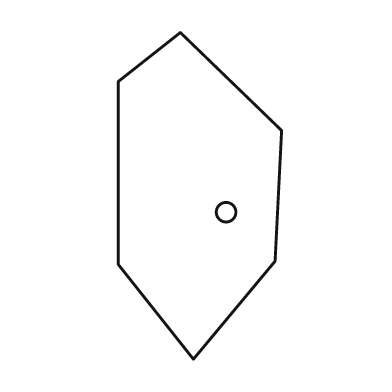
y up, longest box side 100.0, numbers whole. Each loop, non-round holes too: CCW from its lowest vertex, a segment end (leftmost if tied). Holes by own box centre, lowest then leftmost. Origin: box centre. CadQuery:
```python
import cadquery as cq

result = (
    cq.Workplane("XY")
    .moveTo(-2.0, -50.0)
    .lineTo(23.0, -20.0)
    .lineTo(25.0, 20.0)
    .lineTo(-6.0, 50.0)
    .lineTo(-25.0, 35.0)
    .lineTo(-25.0, -21.0)
    .close()
    .moveTo(8.0, -5.0)
    .circle(3.0)
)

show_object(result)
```